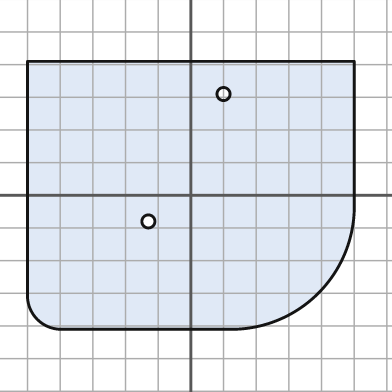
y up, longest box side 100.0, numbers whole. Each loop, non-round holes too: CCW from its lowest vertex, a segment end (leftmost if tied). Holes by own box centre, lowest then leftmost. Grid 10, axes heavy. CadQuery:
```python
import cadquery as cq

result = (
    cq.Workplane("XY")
    .moveTo(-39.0, -41.0)
    .lineTo(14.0, -41.0)
    .threePointArc((39.0, -30.0), (50.0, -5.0))
    .lineTo(50.0, 41.0)
    .lineTo(-50.0, 41.0)
    .lineTo(-50.0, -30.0)
    .threePointArc((-47.0, -38.0), (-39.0, -41.0))
    .close()
    .moveTo(-13.0, -8.0)
    .circle(2.0)
    .moveTo(10.0, 31.0)
    .circle(2.0)
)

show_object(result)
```